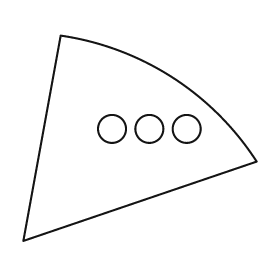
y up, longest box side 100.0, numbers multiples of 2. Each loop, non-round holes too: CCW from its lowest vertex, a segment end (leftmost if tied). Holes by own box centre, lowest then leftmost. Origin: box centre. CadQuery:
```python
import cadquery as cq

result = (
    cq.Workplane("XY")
    .moveTo(-50.0, -44.0)
    .lineTo(50.0, -10.0)
    .threePointArc((14.0, 26.0), (-34.0, 44.0))
    .close()
    .moveTo(-12.0, 4.0)
    .circle(6.0)
    .moveTo(4.0, 4.0)
    .circle(6.0)
    .moveTo(20.0, 4.0)
    .circle(6.0)
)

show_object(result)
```